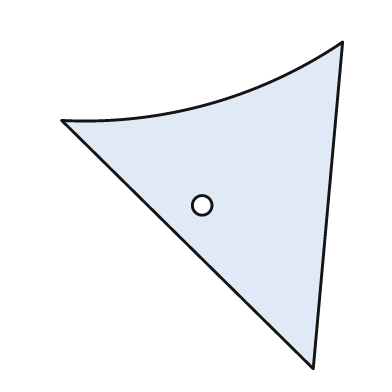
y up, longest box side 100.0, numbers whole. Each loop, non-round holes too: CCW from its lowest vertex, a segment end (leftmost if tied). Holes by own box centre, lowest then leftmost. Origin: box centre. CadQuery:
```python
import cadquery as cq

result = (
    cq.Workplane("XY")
    .moveTo(34.0, -50.0)
    .lineTo(43.0, 50.0)
    .threePointArc((2.0, 31.0), (-43.0, 26.0))
    .close()
    .moveTo(0.0, 0.0)
    .circle(3.0)
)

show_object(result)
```